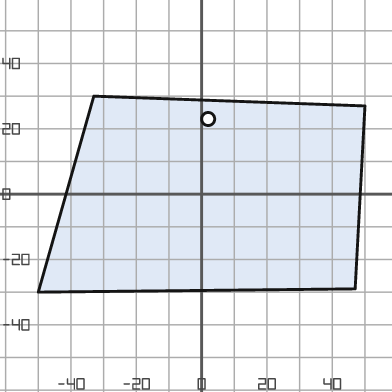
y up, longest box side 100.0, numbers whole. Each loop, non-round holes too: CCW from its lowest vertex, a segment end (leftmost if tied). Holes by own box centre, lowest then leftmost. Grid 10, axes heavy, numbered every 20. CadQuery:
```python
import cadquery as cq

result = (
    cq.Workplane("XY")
    .moveTo(-50.0, -30.0)
    .lineTo(47.0, -29.0)
    .lineTo(50.0, 27.0)
    .lineTo(-33.0, 30.0)
    .close()
    .moveTo(2.0, 23.0)
    .circle(2.0)
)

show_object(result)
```